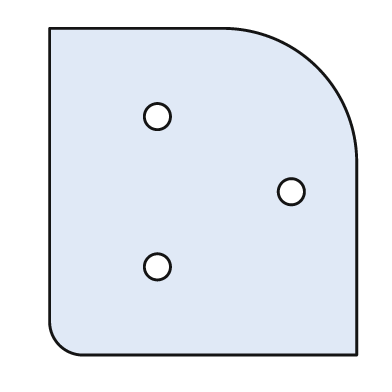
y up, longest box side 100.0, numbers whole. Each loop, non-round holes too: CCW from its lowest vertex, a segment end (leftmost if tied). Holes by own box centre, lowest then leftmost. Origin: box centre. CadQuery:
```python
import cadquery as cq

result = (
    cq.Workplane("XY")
    .moveTo(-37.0, -50.0)
    .lineTo(47.0, -50.0)
    .lineTo(47.0, 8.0)
    .threePointArc((35.0, 38.0), (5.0, 50.0))
    .lineTo(-47.0, 50.0)
    .lineTo(-47.0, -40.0)
    .threePointArc((-44.0, -47.0), (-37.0, -50.0))
    .close()
    .moveTo(-14.0, -23.0)
    .circle(4.0)
    .moveTo(27.0, 0.0)
    .circle(4.0)
    .moveTo(-14.0, 23.0)
    .circle(4.0)
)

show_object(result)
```